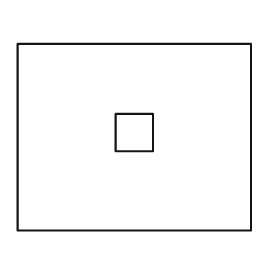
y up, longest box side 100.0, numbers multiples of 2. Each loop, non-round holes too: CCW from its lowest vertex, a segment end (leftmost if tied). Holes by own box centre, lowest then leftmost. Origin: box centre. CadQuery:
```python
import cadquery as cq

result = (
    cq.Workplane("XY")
    .moveTo(-50.0, -40.0)
    .lineTo(50.0, -40.0)
    .lineTo(50.0, 40.0)
    .lineTo(-50.0, 40.0)
    .close()
    .moveTo(-8.0, -6.0)
    .lineTo(8.0, -6.0)
    .lineTo(8.0, 10.0)
    .lineTo(-8.0, 10.0)
    .close()
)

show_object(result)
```